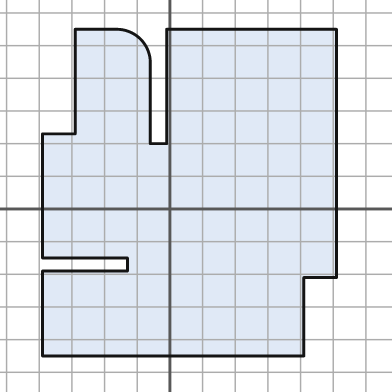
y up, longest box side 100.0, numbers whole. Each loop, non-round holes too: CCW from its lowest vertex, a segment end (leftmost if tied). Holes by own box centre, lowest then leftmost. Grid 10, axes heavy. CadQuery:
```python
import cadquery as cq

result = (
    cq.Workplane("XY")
    .moveTo(-39.0, -45.0)
    .lineTo(41.0, -45.0)
    .lineTo(41.0, -21.0)
    .lineTo(51.0, -21.0)
    .lineTo(51.0, 55.0)
    .lineTo(-1.0, 55.0)
    .lineTo(-1.0, 20.0)
    .lineTo(-6.0, 20.0)
    .lineTo(-6.0, 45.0)
    .threePointArc((-9.0, 52.0), (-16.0, 55.0))
    .lineTo(-29.0, 55.0)
    .lineTo(-29.0, 23.0)
    .lineTo(-39.0, 23.0)
    .lineTo(-39.0, -15.0)
    .lineTo(-13.0, -15.0)
    .lineTo(-13.0, -19.0)
    .lineTo(-39.0, -19.0)
    .close()
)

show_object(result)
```